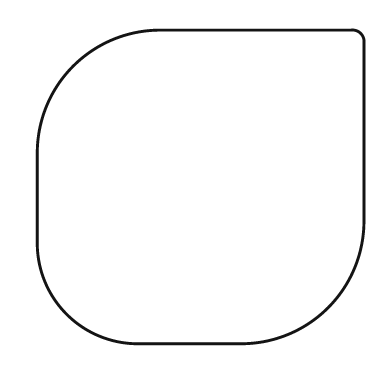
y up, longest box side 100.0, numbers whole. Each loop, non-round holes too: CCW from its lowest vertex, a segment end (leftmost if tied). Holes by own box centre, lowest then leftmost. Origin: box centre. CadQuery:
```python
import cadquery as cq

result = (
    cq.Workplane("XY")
    .moveTo(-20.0, -48.0)
    .lineTo(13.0, -48.0)
    .threePointArc((39.0, -37.0), (50.0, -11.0))
    .lineTo(50.0, 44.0)
    .threePointArc((49.0, 47.0), (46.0, 48.0))
    .lineTo(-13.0, 48.0)
    .threePointArc((-39.0, 37.0), (-50.0, 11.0))
    .lineTo(-50.0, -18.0)
    .threePointArc((-41.0, -39.0), (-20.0, -48.0))
    .close()
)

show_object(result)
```